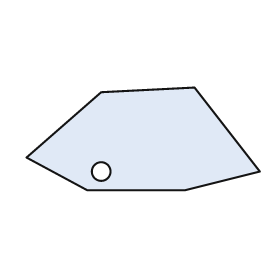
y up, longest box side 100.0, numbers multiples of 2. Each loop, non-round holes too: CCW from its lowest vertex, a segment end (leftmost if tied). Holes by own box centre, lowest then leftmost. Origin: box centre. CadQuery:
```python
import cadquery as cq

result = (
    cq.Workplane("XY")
    .moveTo(-24.0, -22.0)
    .lineTo(18.0, -22.0)
    .lineTo(50.0, -14.0)
    .lineTo(22.0, 22.0)
    .lineTo(-18.0, 20.0)
    .lineTo(-50.0, -8.0)
    .close()
    .moveTo(-18.0, -14.0)
    .circle(4.0)
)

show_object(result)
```